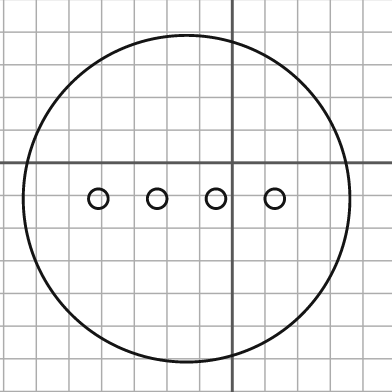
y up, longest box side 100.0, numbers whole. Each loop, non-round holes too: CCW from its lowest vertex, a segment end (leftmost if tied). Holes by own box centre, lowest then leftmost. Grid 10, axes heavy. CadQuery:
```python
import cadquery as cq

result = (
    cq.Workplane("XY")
    .moveTo(-14.0, -11.0)
    .circle(50.0)
    .moveTo(-41.0, -11.0)
    .circle(3.0)
    .moveTo(-23.0, -11.0)
    .circle(3.0)
    .moveTo(-5.0, -11.0)
    .circle(3.0)
    .moveTo(13.0, -11.0)
    .circle(3.0)
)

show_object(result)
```